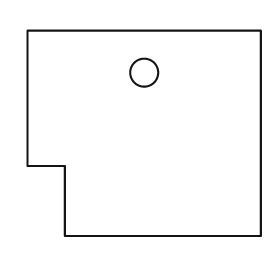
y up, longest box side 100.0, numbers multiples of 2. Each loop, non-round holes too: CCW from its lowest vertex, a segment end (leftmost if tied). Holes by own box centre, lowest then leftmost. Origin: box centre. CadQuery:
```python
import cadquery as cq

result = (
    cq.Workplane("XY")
    .moveTo(-34.0, -44.0)
    .lineTo(50.0, -44.0)
    .lineTo(50.0, 44.0)
    .lineTo(-50.0, 44.0)
    .lineTo(-50.0, -14.0)
    .lineTo(-34.0, -14.0)
    .close()
    .moveTo(0.0, 26.0)
    .circle(6.0)
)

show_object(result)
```